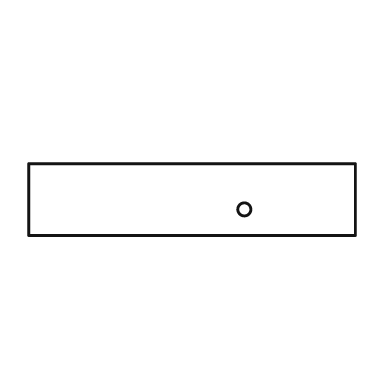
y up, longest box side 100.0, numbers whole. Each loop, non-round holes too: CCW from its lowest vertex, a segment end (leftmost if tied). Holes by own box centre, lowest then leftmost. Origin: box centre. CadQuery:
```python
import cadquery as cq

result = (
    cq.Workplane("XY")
    .moveTo(-50.0, -11.0)
    .lineTo(50.0, -11.0)
    .lineTo(50.0, 11.0)
    .lineTo(-50.0, 11.0)
    .close()
    .moveTo(16.0, -3.0)
    .circle(2.0)
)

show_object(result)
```